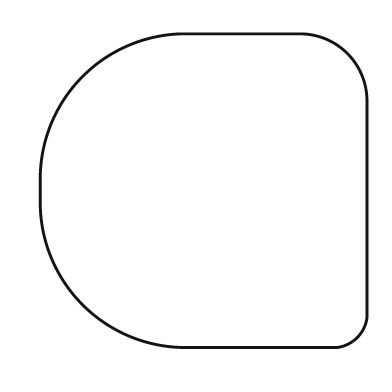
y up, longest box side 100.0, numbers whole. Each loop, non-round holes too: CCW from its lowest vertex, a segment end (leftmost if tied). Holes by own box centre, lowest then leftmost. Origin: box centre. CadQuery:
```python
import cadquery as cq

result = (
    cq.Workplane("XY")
    .moveTo(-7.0, -48.0)
    .lineTo(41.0, -48.0)
    .threePointArc((47.0, -45.0), (50.0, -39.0))
    .lineTo(50.0, 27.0)
    .threePointArc((44.0, 42.0), (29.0, 48.0))
    .lineTo(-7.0, 48.0)
    .threePointArc((-37.0, 35.0), (-50.0, 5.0))
    .lineTo(-50.0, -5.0)
    .threePointArc((-37.0, -35.0), (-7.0, -48.0))
    .close()
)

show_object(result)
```